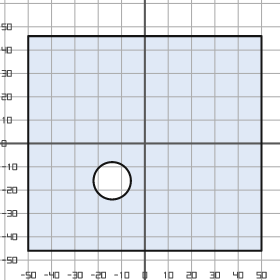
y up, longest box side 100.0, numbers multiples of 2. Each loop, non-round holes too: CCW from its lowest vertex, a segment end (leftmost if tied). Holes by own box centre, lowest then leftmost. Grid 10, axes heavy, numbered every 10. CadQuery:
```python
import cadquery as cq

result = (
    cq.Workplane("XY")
    .moveTo(-50.0, -46.0)
    .lineTo(50.0, -46.0)
    .lineTo(50.0, 46.0)
    .lineTo(-50.0, 46.0)
    .close()
    .moveTo(-14.0, -16.0)
    .circle(8.0)
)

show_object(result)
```